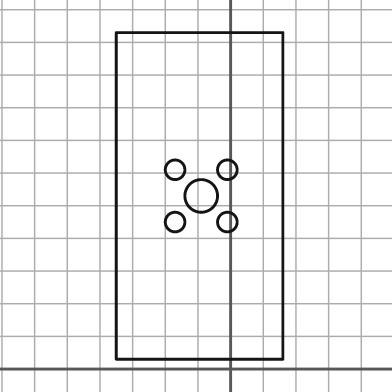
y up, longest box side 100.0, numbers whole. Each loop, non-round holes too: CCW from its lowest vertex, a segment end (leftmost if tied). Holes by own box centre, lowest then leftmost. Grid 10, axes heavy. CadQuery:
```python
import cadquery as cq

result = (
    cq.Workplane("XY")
    .moveTo(-35.0, 3.0)
    .lineTo(16.0, 3.0)
    .lineTo(16.0, 103.0)
    .lineTo(-35.0, 103.0)
    .close()
    .moveTo(-17.0, 45.0)
    .circle(3.0)
    .moveTo(-1.0, 45.0)
    .circle(3.0)
    .moveTo(-9.0, 53.0)
    .circle(5.0)
    .moveTo(-17.0, 61.0)
    .circle(3.0)
    .moveTo(-1.0, 61.0)
    .circle(3.0)
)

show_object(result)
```